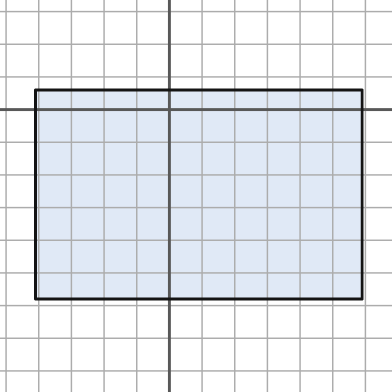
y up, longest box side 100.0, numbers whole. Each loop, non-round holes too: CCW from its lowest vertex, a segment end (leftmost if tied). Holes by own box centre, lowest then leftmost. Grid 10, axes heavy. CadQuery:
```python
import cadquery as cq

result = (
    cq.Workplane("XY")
    .moveTo(-41.0, -58.0)
    .lineTo(59.0, -58.0)
    .lineTo(59.0, 6.0)
    .lineTo(-41.0, 6.0)
    .close()
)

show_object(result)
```